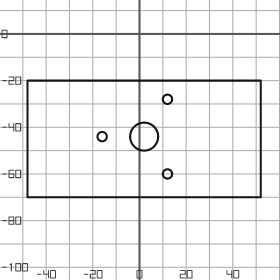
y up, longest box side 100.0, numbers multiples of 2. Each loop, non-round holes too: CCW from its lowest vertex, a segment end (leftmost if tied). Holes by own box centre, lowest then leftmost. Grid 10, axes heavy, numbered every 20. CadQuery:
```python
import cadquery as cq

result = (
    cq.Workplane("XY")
    .moveTo(-48.0, -70.0)
    .lineTo(52.0, -70.0)
    .lineTo(52.0, -20.0)
    .lineTo(-48.0, -20.0)
    .close()
    .moveTo(12.0, -60.0)
    .circle(2.0)
    .moveTo(-16.0, -44.0)
    .circle(2.0)
    .moveTo(2.0, -44.0)
    .circle(6.0)
    .moveTo(12.0, -28.0)
    .circle(2.0)
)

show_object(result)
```